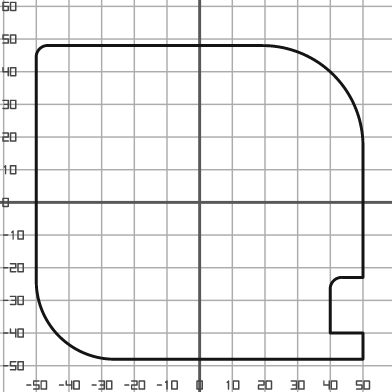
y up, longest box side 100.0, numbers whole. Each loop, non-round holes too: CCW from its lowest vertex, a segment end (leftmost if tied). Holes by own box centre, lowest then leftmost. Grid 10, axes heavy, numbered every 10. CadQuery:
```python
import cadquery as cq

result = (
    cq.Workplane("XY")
    .moveTo(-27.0, -48.0)
    .lineTo(50.0, -48.0)
    .lineTo(50.0, -40.0)
    .lineTo(40.0, -40.0)
    .lineTo(40.0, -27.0)
    .threePointArc((41.0, -24.0), (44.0, -23.0))
    .lineTo(50.0, -23.0)
    .lineTo(50.0, 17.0)
    .threePointArc((41.0, 39.0), (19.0, 48.0))
    .lineTo(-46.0, 48.0)
    .threePointArc((-49.0, 47.0), (-50.0, 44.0))
    .lineTo(-50.0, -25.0)
    .threePointArc((-43.0, -41.0), (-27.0, -48.0))
    .close()
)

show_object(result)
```